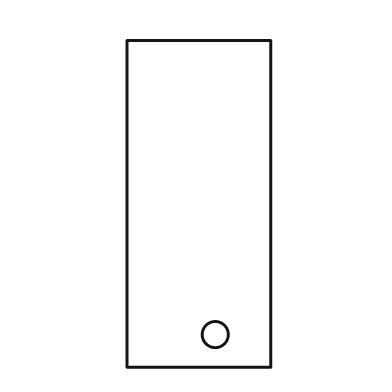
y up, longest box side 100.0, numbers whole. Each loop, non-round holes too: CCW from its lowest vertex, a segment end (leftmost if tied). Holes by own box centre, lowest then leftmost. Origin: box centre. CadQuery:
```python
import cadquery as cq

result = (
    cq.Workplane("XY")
    .moveTo(-22.0, -50.0)
    .lineTo(22.0, -50.0)
    .lineTo(22.0, 50.0)
    .lineTo(-22.0, 50.0)
    .close()
    .moveTo(5.0, -40.0)
    .circle(4.0)
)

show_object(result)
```